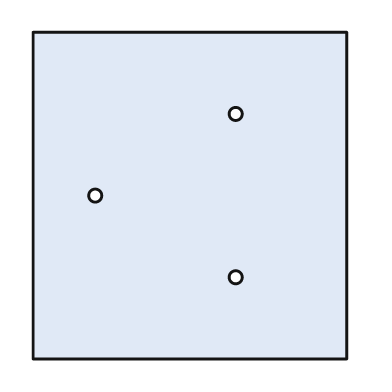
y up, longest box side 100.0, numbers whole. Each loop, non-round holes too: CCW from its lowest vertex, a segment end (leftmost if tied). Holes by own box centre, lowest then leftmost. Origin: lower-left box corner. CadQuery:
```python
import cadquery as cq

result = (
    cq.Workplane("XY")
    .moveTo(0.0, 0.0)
    .lineTo(96.0, 0.0)
    .lineTo(96.0, 100.0)
    .lineTo(0.0, 100.0)
    .close()
    .moveTo(62.0, 25.0)
    .circle(2.0)
    .moveTo(19.0, 50.0)
    .circle(2.0)
    .moveTo(62.0, 75.0)
    .circle(2.0)
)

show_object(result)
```